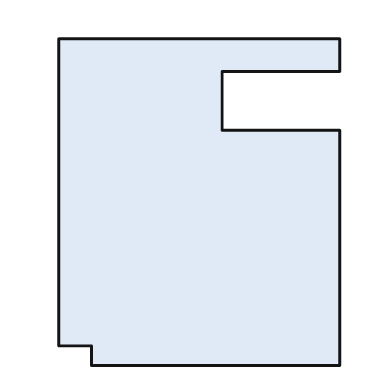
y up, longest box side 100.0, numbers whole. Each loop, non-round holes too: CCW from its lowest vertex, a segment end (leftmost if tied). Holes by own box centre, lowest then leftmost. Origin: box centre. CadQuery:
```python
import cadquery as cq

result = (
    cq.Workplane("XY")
    .moveTo(-33.0, -50.0)
    .lineTo(43.0, -50.0)
    .lineTo(43.0, 22.0)
    .lineTo(7.0, 22.0)
    .lineTo(7.0, 40.0)
    .lineTo(43.0, 40.0)
    .lineTo(43.0, 50.0)
    .lineTo(-43.0, 50.0)
    .lineTo(-43.0, -44.0)
    .lineTo(-33.0, -44.0)
    .close()
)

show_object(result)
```